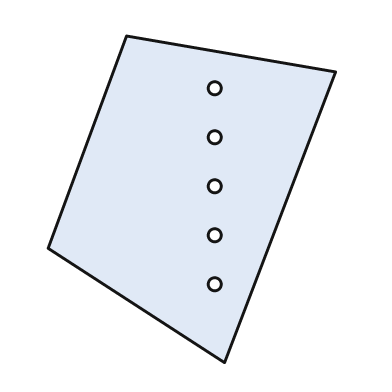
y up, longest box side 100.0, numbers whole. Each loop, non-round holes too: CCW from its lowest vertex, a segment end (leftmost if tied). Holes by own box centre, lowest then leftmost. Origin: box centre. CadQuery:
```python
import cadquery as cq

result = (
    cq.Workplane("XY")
    .moveTo(10.0, -50.0)
    .lineTo(44.0, 39.0)
    .lineTo(-20.0, 50.0)
    .lineTo(-44.0, -15.0)
    .close()
    .moveTo(7.0, -26.0)
    .circle(2.0)
    .moveTo(7.0, -11.0)
    .circle(2.0)
    .moveTo(7.0, 4.0)
    .circle(2.0)
    .moveTo(7.0, 19.0)
    .circle(2.0)
    .moveTo(7.0, 34.0)
    .circle(2.0)
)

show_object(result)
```